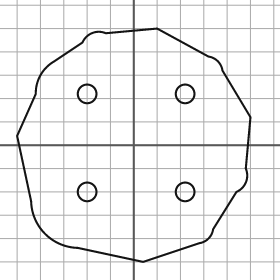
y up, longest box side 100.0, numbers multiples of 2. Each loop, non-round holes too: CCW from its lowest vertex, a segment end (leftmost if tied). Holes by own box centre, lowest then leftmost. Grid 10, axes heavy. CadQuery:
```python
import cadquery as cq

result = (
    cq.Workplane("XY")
    .moveTo(4.0, -50.0)
    .lineTo(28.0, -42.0)
    .threePointArc((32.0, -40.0), (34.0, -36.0))
    .lineTo(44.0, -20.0)
    .threePointArc((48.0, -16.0), (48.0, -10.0))
    .lineTo(50.0, 12.0)
    .lineTo(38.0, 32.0)
    .threePointArc((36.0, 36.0), (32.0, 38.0))
    .lineTo(10.0, 50.0)
    .lineTo(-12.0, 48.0)
    .threePointArc((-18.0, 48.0), (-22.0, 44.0))
    .lineTo(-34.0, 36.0)
    .threePointArc((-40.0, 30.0), (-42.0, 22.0))
    .lineTo(-50.0, 4.0)
    .lineTo(-44.0, -24.0)
    .threePointArc((-38.0, -38.0), (-24.0, -44.0))
    .close()
    .moveTo(-20.0, -20.0)
    .circle(4.0)
    .moveTo(22.0, -20.0)
    .circle(4.0)
    .moveTo(-20.0, 22.0)
    .circle(4.0)
    .moveTo(22.0, 22.0)
    .circle(4.0)
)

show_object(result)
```